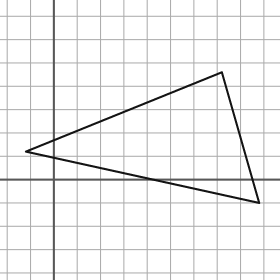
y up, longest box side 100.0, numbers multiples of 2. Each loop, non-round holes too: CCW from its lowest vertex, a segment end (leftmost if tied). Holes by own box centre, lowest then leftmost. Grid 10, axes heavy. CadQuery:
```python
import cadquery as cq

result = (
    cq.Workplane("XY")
    .moveTo(88.0, -10.0)
    .lineTo(72.0, 46.0)
    .lineTo(-12.0, 12.0)
    .close()
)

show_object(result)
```